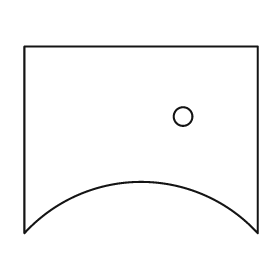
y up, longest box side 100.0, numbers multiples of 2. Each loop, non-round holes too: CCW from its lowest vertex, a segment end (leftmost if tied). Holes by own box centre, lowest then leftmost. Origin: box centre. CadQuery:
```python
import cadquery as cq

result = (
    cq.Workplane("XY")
    .moveTo(-50.0, -40.0)
    .threePointArc((0.0, -18.0), (50.0, -40.0))
    .lineTo(50.0, 40.0)
    .lineTo(-50.0, 40.0)
    .close()
    .moveTo(18.0, 10.0)
    .circle(4.0)
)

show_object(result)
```